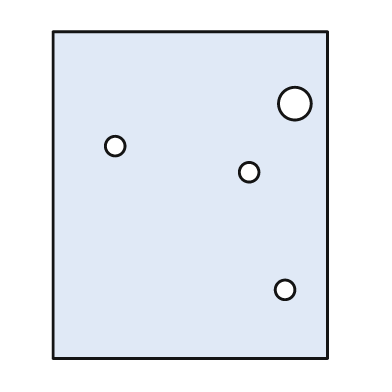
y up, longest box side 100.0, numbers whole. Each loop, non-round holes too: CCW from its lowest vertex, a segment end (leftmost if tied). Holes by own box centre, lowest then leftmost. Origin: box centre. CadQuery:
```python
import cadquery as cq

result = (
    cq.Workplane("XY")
    .moveTo(-42.0, -50.0)
    .lineTo(42.0, -50.0)
    .lineTo(42.0, 50.0)
    .lineTo(-42.0, 50.0)
    .close()
    .moveTo(29.0, -29.0)
    .circle(3.0)
    .moveTo(18.0, 7.0)
    .circle(3.0)
    .moveTo(-23.0, 15.0)
    .circle(3.0)
    .moveTo(32.0, 28.0)
    .circle(5.0)
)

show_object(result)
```